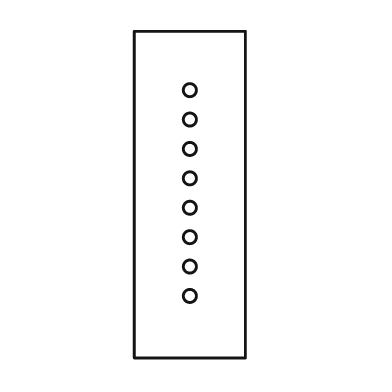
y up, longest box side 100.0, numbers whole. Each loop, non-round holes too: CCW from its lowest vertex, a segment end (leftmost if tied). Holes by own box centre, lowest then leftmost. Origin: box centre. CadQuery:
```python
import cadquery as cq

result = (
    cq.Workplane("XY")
    .moveTo(-17.0, -50.0)
    .lineTo(17.0, -50.0)
    .lineTo(17.0, 50.0)
    .lineTo(-17.0, 50.0)
    .close()
    .moveTo(0.0, -31.0)
    .circle(2.0)
    .moveTo(0.0, -22.0)
    .circle(2.0)
    .moveTo(0.0, -13.0)
    .circle(2.0)
    .moveTo(0.0, -4.0)
    .circle(2.0)
    .moveTo(0.0, 5.0)
    .circle(2.0)
    .moveTo(0.0, 14.0)
    .circle(2.0)
    .moveTo(0.0, 23.0)
    .circle(2.0)
    .moveTo(0.0, 32.0)
    .circle(2.0)
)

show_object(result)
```